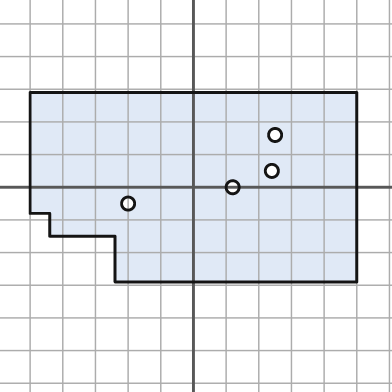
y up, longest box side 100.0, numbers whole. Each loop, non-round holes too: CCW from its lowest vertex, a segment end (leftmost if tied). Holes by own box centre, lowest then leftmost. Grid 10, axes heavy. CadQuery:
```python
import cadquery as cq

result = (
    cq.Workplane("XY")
    .moveTo(-24.0, -29.0)
    .lineTo(50.0, -29.0)
    .lineTo(50.0, 29.0)
    .lineTo(-50.0, 29.0)
    .lineTo(-50.0, -8.0)
    .lineTo(-44.0, -8.0)
    .lineTo(-44.0, -15.0)
    .lineTo(-24.0, -15.0)
    .close()
    .moveTo(-20.0, -5.0)
    .circle(2.0)
    .moveTo(12.0, 0.0)
    .circle(2.0)
    .moveTo(24.0, 5.0)
    .circle(2.0)
    .moveTo(25.0, 16.0)
    .circle(2.0)
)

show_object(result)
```